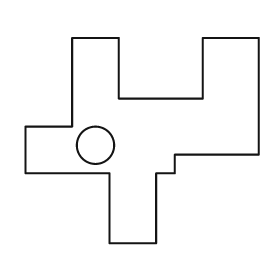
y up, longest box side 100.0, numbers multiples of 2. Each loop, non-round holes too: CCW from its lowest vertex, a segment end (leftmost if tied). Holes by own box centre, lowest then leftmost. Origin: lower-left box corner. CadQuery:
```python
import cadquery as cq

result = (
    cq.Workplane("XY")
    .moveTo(36.0, 0.0)
    .lineTo(56.0, 0.0)
    .lineTo(56.0, 30.0)
    .lineTo(64.0, 30.0)
    .lineTo(64.0, 38.0)
    .lineTo(100.0, 38.0)
    .lineTo(100.0, 88.0)
    .lineTo(76.0, 88.0)
    .lineTo(76.0, 62.0)
    .lineTo(40.0, 62.0)
    .lineTo(40.0, 88.0)
    .lineTo(20.0, 88.0)
    .lineTo(20.0, 50.0)
    .lineTo(0.0, 50.0)
    .lineTo(0.0, 30.0)
    .lineTo(36.0, 30.0)
    .close()
    .moveTo(30.0, 42.0)
    .circle(8.0)
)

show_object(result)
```